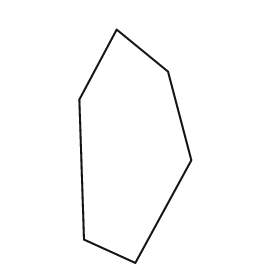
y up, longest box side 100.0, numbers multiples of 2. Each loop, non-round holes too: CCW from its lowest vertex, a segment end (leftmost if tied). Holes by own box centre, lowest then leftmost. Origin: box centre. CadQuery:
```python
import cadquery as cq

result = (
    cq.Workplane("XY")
    .moveTo(0.0, -50.0)
    .lineTo(24.0, -6.0)
    .lineTo(14.0, 32.0)
    .lineTo(-8.0, 50.0)
    .lineTo(-24.0, 20.0)
    .lineTo(-22.0, -40.0)
    .close()
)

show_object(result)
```